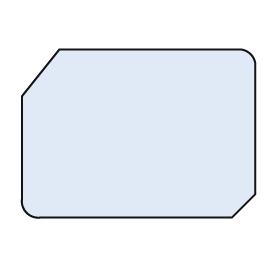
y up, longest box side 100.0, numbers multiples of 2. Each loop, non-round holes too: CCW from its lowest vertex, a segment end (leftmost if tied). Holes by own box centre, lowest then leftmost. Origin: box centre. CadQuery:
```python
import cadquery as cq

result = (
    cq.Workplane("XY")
    .moveTo(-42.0, -36.0)
    .lineTo(40.0, -36.0)
    .lineTo(50.0, -26.0)
    .lineTo(50.0, 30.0)
    .threePointArc((48.0, 34.0), (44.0, 36.0))
    .lineTo(-34.0, 36.0)
    .lineTo(-50.0, 16.0)
    .lineTo(-50.0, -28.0)
    .threePointArc((-48.0, -34.0), (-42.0, -36.0))
    .close()
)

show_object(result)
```